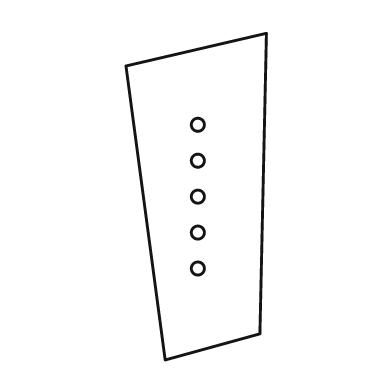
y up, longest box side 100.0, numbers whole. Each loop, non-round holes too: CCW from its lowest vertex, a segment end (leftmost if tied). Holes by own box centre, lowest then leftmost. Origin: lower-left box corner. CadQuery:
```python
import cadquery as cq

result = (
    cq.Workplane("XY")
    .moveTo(12.0, 0.0)
    .lineTo(41.0, 8.0)
    .lineTo(43.0, 100.0)
    .lineTo(0.0, 90.0)
    .close()
    .moveTo(22.0, 28.0)
    .circle(2.0)
    .moveTo(22.0, 39.0)
    .circle(2.0)
    .moveTo(22.0, 50.0)
    .circle(2.0)
    .moveTo(22.0, 61.0)
    .circle(2.0)
    .moveTo(22.0, 72.0)
    .circle(2.0)
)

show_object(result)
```